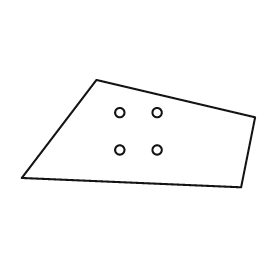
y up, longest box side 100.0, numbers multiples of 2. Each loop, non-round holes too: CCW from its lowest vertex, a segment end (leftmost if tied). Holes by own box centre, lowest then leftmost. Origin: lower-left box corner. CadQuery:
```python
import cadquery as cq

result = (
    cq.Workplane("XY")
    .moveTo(94.0, 0.0)
    .lineTo(100.0, 30.0)
    .lineTo(32.0, 46.0)
    .lineTo(0.0, 4.0)
    .close()
    .moveTo(42.0, 16.0)
    .circle(2.0)
    .moveTo(58.0, 16.0)
    .circle(2.0)
    .moveTo(42.0, 32.0)
    .circle(2.0)
    .moveTo(58.0, 32.0)
    .circle(2.0)
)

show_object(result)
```